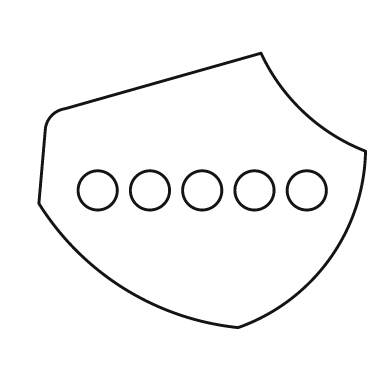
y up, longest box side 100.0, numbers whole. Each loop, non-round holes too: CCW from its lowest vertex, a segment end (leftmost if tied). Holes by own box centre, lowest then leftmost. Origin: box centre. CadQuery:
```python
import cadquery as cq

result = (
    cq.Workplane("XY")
    .moveTo(11.0, -42.0)
    .threePointArc((39.0, -21.0), (50.0, 12.0))
    .threePointArc((31.0, 24.0), (18.0, 42.0))
    .lineTo(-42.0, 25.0)
    .threePointArc((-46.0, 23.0), (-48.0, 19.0))
    .lineTo(-50.0, -4.0)
    .threePointArc((-24.0, -30.0), (11.0, -42.0))
    .close()
    .moveTo(-32.0, 0.0)
    .circle(6.0)
    .moveTo(-16.0, 0.0)
    .circle(6.0)
    .moveTo(0.0, 0.0)
    .circle(6.0)
    .moveTo(16.0, 0.0)
    .circle(6.0)
    .moveTo(32.0, 0.0)
    .circle(6.0)
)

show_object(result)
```